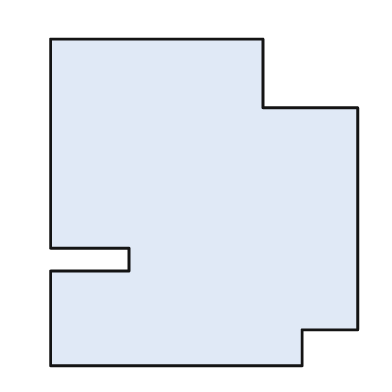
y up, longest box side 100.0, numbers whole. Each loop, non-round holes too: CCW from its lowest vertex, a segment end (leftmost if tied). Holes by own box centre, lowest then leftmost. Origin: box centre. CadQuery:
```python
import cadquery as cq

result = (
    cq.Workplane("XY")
    .moveTo(-47.0, -50.0)
    .lineTo(30.0, -50.0)
    .lineTo(30.0, -39.0)
    .lineTo(47.0, -39.0)
    .lineTo(47.0, 29.0)
    .lineTo(18.0, 29.0)
    .lineTo(18.0, 50.0)
    .lineTo(-47.0, 50.0)
    .lineTo(-47.0, -14.0)
    .lineTo(-23.0, -14.0)
    .lineTo(-23.0, -21.0)
    .lineTo(-47.0, -21.0)
    .close()
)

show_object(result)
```